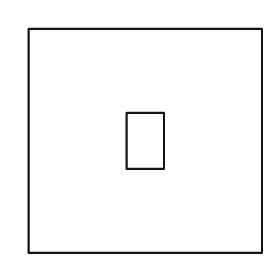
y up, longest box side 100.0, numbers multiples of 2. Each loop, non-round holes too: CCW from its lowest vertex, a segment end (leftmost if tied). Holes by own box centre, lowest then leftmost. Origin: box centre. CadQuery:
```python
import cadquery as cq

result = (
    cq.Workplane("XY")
    .moveTo(-50.0, -48.0)
    .lineTo(50.0, -48.0)
    .lineTo(50.0, 48.0)
    .lineTo(-50.0, 48.0)
    .close()
    .moveTo(-8.0, -12.0)
    .lineTo(8.0, -12.0)
    .lineTo(8.0, 12.0)
    .lineTo(-8.0, 12.0)
    .close()
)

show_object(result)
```